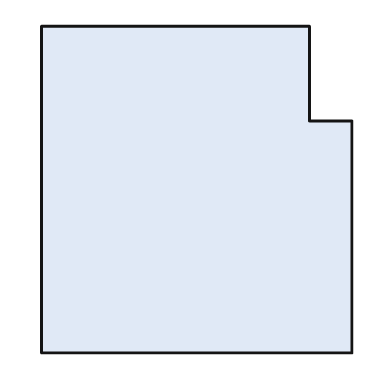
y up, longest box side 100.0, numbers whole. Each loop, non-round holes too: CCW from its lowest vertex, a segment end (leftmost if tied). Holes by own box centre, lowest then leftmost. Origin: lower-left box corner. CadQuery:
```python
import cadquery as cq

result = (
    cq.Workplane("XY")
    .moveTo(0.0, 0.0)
    .lineTo(95.0, 0.0)
    .lineTo(95.0, 71.0)
    .lineTo(82.0, 71.0)
    .lineTo(82.0, 100.0)
    .lineTo(0.0, 100.0)
    .close()
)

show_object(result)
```